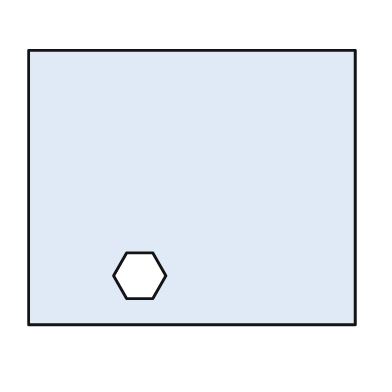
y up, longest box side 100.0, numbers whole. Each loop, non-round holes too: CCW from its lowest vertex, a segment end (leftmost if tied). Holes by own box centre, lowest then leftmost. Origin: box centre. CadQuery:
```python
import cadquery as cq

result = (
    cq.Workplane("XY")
    .moveTo(-50.0, -42.0)
    .lineTo(50.0, -42.0)
    .lineTo(50.0, 42.0)
    .lineTo(-50.0, 42.0)
    .close()
    .moveTo(-20.0, -34.0)
    .lineTo(-12.0, -34.0)
    .lineTo(-8.0, -27.0)
    .lineTo(-12.0, -20.0)
    .lineTo(-20.0, -20.0)
    .lineTo(-24.0, -27.0)
    .close()
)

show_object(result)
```